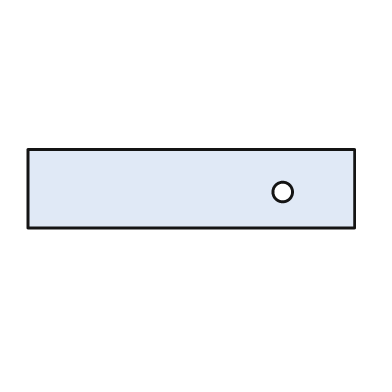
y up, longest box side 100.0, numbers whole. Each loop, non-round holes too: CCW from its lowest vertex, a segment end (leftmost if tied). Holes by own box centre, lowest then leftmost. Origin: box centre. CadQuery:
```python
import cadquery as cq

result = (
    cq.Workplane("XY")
    .moveTo(-50.0, -12.0)
    .lineTo(50.0, -12.0)
    .lineTo(50.0, 12.0)
    .lineTo(-50.0, 12.0)
    .close()
    .moveTo(28.0, -1.0)
    .circle(3.0)
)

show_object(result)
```